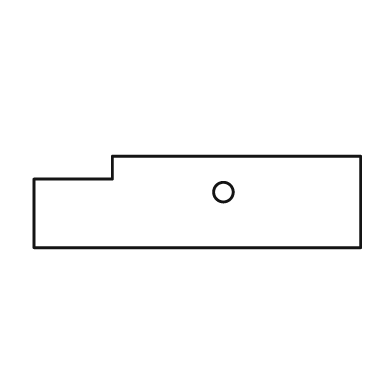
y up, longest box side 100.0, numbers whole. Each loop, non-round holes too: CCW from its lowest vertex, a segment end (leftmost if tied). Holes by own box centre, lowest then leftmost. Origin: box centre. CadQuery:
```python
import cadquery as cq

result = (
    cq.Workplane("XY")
    .moveTo(-50.0, -14.0)
    .lineTo(50.0, -14.0)
    .lineTo(50.0, 14.0)
    .lineTo(-26.0, 14.0)
    .lineTo(-26.0, 7.0)
    .lineTo(-50.0, 7.0)
    .close()
    .moveTo(8.0, 3.0)
    .circle(3.0)
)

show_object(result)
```